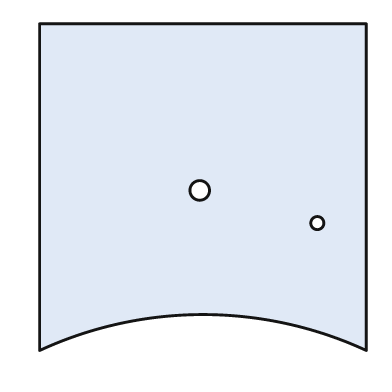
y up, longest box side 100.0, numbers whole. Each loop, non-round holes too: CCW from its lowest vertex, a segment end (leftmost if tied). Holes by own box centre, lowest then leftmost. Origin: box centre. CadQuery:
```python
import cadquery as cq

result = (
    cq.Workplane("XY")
    .moveTo(-50.0, -50.0)
    .threePointArc((0.0, -39.0), (50.0, -50.0))
    .lineTo(50.0, 50.0)
    .lineTo(-50.0, 50.0)
    .close()
    .moveTo(35.0, -11.0)
    .circle(2.0)
    .moveTo(-1.0, -1.0)
    .circle(3.0)
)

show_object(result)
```